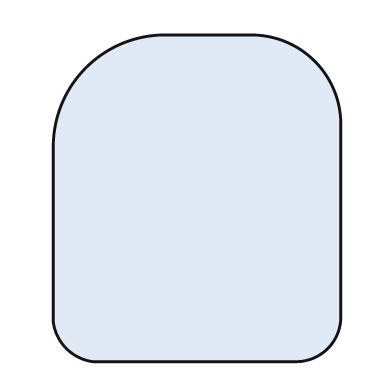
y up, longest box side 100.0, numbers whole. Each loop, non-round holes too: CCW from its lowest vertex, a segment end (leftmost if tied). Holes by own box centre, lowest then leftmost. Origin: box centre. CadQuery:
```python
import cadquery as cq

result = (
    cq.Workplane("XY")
    .moveTo(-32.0, -50.0)
    .lineTo(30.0, -50.0)
    .threePointArc((40.0, -46.0), (44.0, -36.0))
    .lineTo(44.0, 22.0)
    .threePointArc((36.0, 42.0), (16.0, 50.0))
    .lineTo(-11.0, 50.0)
    .threePointArc((-34.0, 40.0), (-44.0, 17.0))
    .lineTo(-44.0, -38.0)
    .threePointArc((-40.0, -46.0), (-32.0, -50.0))
    .close()
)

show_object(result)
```